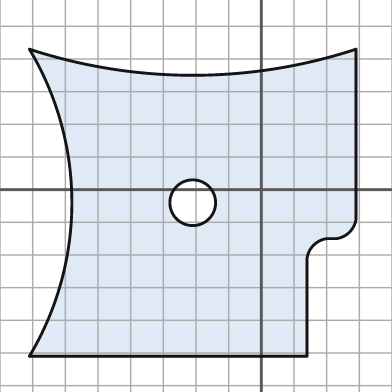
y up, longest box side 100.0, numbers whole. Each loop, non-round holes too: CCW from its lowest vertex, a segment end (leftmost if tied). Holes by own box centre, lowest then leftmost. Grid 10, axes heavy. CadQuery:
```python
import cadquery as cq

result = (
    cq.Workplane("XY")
    .moveTo(-71.0, -51.0)
    .lineTo(14.0, -51.0)
    .lineTo(14.0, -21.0)
    .threePointArc((16.0, -17.0), (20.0, -15.0))
    .lineTo(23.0, -15.0)
    .threePointArc((27.0, -13.0), (29.0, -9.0))
    .lineTo(29.0, 43.0)
    .threePointArc((-21.0, 35.0), (-71.0, 43.0))
    .threePointArc((-58.0, -4.0), (-71.0, -51.0))
    .close()
    .moveTo(-21.0, -4.0)
    .circle(7.0)
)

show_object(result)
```